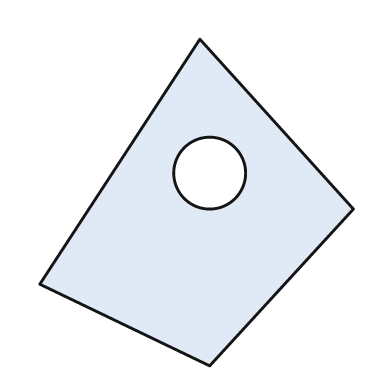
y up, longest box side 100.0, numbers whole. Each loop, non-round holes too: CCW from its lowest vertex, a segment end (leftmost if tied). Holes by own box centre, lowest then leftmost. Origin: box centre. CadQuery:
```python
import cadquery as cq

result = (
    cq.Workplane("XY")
    .moveTo(4.0, -50.0)
    .lineTo(48.0, -2.0)
    .lineTo(1.0, 50.0)
    .lineTo(-48.0, -25.0)
    .close()
    .moveTo(4.0, 9.0)
    .circle(11.0)
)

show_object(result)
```